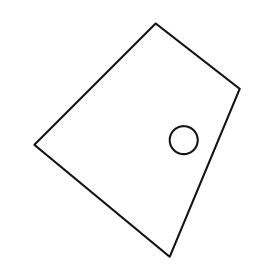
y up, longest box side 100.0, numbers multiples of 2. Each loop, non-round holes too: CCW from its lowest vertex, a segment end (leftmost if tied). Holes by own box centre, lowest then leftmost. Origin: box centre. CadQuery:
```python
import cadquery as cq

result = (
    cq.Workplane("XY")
    .moveTo(14.0, -50.0)
    .lineTo(44.0, 22.0)
    .lineTo(8.0, 50.0)
    .lineTo(-44.0, -2.0)
    .close()
    .moveTo(20.0, 0.0)
    .circle(6.0)
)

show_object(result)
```